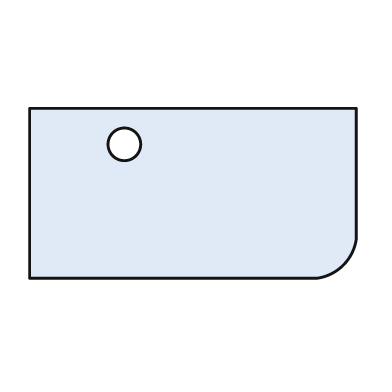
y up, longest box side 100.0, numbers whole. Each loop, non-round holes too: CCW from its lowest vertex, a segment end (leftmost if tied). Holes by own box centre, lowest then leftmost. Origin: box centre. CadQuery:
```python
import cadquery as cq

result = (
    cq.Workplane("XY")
    .moveTo(-50.0, -26.0)
    .lineTo(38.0, -26.0)
    .threePointArc((46.0, -22.0), (50.0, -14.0))
    .lineTo(50.0, 26.0)
    .lineTo(-50.0, 26.0)
    .close()
    .moveTo(-21.0, 15.0)
    .circle(5.0)
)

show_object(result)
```